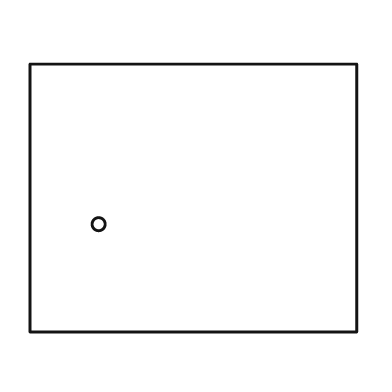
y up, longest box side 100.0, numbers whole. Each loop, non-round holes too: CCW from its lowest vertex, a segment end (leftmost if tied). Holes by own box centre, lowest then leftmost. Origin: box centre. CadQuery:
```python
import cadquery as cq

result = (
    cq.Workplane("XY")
    .moveTo(-50.0, -41.0)
    .lineTo(50.0, -41.0)
    .lineTo(50.0, 41.0)
    .lineTo(-50.0, 41.0)
    .close()
    .moveTo(-29.0, -8.0)
    .circle(2.0)
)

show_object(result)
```